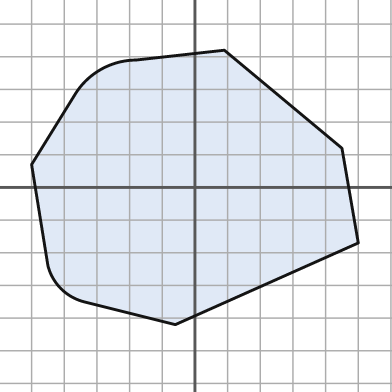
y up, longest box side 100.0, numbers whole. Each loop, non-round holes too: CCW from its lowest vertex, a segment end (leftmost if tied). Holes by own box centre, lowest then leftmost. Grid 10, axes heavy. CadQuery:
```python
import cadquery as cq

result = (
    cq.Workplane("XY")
    .moveTo(-6.0, -42.0)
    .lineTo(50.0, -17.0)
    .lineTo(45.0, 12.0)
    .lineTo(9.0, 42.0)
    .lineTo(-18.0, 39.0)
    .threePointArc((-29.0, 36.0), (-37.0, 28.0))
    .lineTo(-50.0, 7.0)
    .lineTo(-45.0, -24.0)
    .threePointArc((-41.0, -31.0), (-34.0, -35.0))
    .close()
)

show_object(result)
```